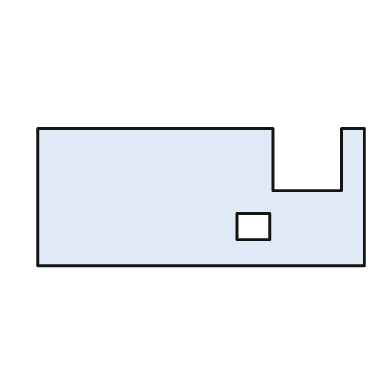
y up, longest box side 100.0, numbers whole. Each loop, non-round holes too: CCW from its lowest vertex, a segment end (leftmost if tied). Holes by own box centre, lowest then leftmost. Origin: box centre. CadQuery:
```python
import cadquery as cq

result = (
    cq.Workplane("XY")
    .moveTo(-50.0, -21.0)
    .lineTo(50.0, -21.0)
    .lineTo(50.0, 21.0)
    .lineTo(43.0, 21.0)
    .lineTo(43.0, 2.0)
    .lineTo(22.0, 2.0)
    .lineTo(22.0, 21.0)
    .lineTo(-50.0, 21.0)
    .close()
    .moveTo(11.0, -13.0)
    .lineTo(21.0, -13.0)
    .lineTo(21.0, -5.0)
    .lineTo(11.0, -5.0)
    .close()
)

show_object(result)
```